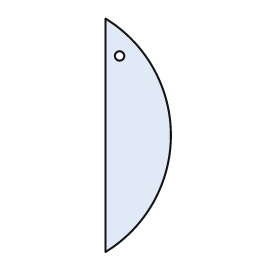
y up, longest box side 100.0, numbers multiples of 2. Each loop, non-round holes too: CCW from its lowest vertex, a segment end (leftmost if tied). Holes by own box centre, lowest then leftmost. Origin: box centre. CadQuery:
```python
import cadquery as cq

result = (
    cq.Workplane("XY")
    .moveTo(-14.0, -50.0)
    .threePointArc((14.0, 0.0), (-14.0, 50.0))
    .close()
    .moveTo(-8.0, 34.0)
    .circle(2.0)
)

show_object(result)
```